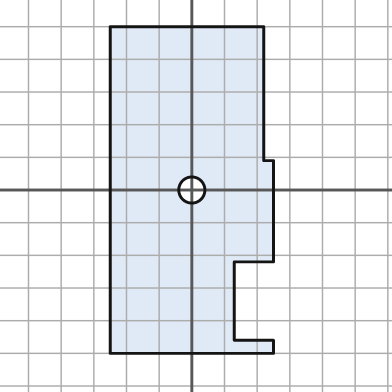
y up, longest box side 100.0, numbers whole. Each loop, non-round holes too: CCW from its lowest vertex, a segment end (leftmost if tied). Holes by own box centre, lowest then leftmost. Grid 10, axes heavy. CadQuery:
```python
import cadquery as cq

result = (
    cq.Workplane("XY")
    .moveTo(-25.0, -50.0)
    .lineTo(25.0, -50.0)
    .lineTo(25.0, -46.0)
    .lineTo(13.0, -46.0)
    .lineTo(13.0, -22.0)
    .lineTo(25.0, -22.0)
    .lineTo(25.0, 9.0)
    .lineTo(22.0, 9.0)
    .lineTo(22.0, 50.0)
    .lineTo(-25.0, 50.0)
    .close()
    .moveTo(0.0, 0.0)
    .circle(4.0)
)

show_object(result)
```